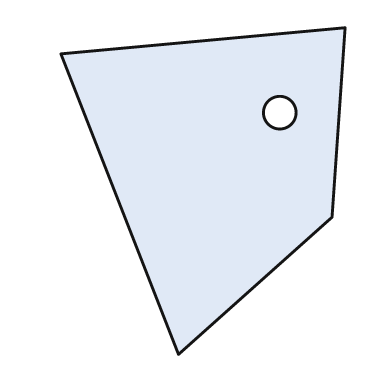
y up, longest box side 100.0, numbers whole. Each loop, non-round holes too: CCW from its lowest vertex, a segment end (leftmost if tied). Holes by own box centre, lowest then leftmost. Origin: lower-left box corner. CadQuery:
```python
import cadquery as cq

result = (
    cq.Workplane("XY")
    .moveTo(36.0, 0.0)
    .lineTo(83.0, 42.0)
    .lineTo(87.0, 100.0)
    .lineTo(0.0, 92.0)
    .close()
    .moveTo(67.0, 74.0)
    .circle(5.0)
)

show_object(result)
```